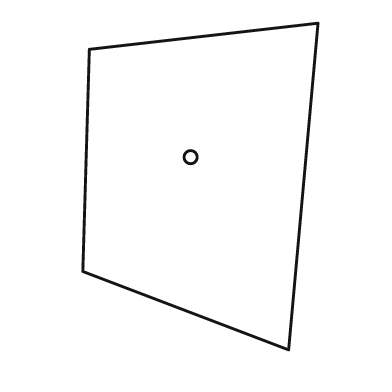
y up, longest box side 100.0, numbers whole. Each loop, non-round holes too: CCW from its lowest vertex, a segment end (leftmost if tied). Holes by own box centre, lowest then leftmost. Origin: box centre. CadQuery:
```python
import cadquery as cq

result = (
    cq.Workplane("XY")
    .moveTo(27.0, -50.0)
    .lineTo(36.0, 50.0)
    .lineTo(-34.0, 42.0)
    .lineTo(-36.0, -26.0)
    .close()
    .moveTo(-3.0, 9.0)
    .circle(2.0)
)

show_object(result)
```